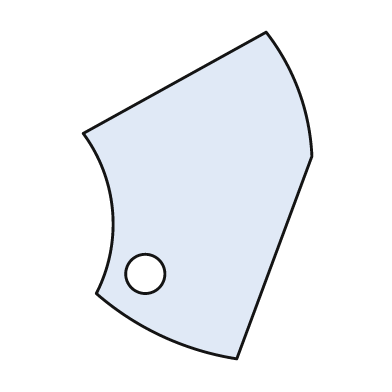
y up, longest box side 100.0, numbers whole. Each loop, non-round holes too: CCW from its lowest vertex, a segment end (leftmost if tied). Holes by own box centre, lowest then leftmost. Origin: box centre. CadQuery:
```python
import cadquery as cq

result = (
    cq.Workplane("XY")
    .moveTo(12.0, -50.0)
    .lineTo(35.0, 12.0)
    .threePointArc((31.0, 32.0), (21.0, 50.0))
    .lineTo(-35.0, 19.0)
    .threePointArc((-26.0, -5.0), (-31.0, -30.0))
    .threePointArc((-11.0, -43.0), (12.0, -50.0))
    .close()
    .moveTo(-16.0, -24.0)
    .circle(6.0)
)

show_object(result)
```